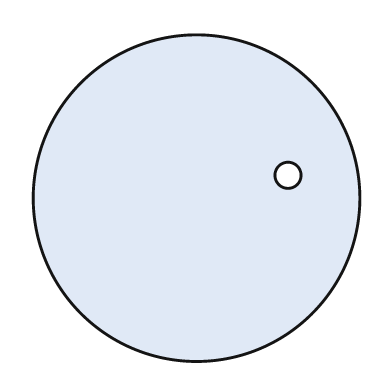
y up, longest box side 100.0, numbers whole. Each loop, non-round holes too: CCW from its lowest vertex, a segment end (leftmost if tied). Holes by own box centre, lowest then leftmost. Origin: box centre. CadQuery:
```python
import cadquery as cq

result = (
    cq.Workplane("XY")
    .moveTo(0.0, 0.0)
    .circle(50.0)
    .moveTo(28.0, 7.0)
    .circle(4.0)
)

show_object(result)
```